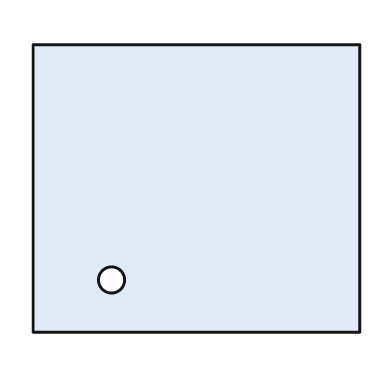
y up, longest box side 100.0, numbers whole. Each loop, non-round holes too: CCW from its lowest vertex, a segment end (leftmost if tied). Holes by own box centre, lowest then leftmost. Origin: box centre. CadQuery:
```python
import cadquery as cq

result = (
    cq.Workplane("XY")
    .moveTo(-50.0, -44.0)
    .lineTo(50.0, -44.0)
    .lineTo(50.0, 44.0)
    .lineTo(-50.0, 44.0)
    .close()
    .moveTo(-26.0, -28.0)
    .circle(4.0)
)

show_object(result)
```